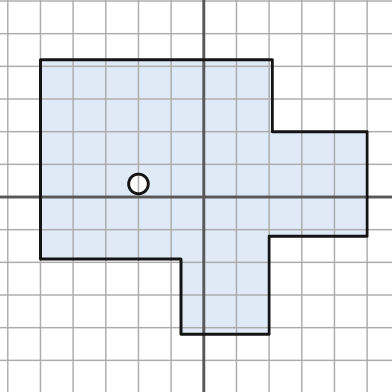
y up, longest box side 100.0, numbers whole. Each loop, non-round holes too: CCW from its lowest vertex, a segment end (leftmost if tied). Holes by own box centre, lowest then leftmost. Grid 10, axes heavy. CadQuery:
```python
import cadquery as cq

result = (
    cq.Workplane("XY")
    .moveTo(-7.0, -42.0)
    .lineTo(20.0, -42.0)
    .lineTo(20.0, -12.0)
    .lineTo(50.0, -12.0)
    .lineTo(50.0, 20.0)
    .lineTo(21.0, 20.0)
    .lineTo(21.0, 42.0)
    .lineTo(-50.0, 42.0)
    .lineTo(-50.0, -19.0)
    .lineTo(-7.0, -19.0)
    .close()
    .moveTo(-20.0, 4.0)
    .circle(3.0)
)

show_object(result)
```